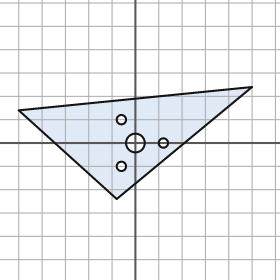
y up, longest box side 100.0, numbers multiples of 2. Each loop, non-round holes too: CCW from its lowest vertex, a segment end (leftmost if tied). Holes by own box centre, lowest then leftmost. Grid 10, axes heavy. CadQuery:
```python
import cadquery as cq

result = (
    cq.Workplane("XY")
    .moveTo(-8.0, -24.0)
    .lineTo(50.0, 24.0)
    .lineTo(-50.0, 14.0)
    .close()
    .moveTo(-6.0, -10.0)
    .circle(2.0)
    .moveTo(0.0, 0.0)
    .circle(4.0)
    .moveTo(12.0, 0.0)
    .circle(2.0)
    .moveTo(-6.0, 10.0)
    .circle(2.0)
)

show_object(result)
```